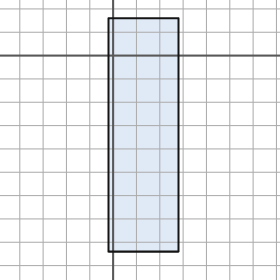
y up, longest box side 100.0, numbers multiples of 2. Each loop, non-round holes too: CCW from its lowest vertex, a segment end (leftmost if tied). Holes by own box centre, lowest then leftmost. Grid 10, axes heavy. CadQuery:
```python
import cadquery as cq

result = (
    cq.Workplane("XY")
    .moveTo(-2.0, -84.0)
    .lineTo(28.0, -84.0)
    .lineTo(28.0, 16.0)
    .lineTo(-2.0, 16.0)
    .close()
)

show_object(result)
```